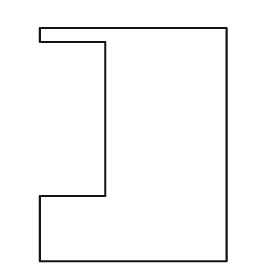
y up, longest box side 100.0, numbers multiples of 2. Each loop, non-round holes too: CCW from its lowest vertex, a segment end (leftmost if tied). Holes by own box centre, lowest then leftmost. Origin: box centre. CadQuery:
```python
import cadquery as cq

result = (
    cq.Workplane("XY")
    .moveTo(-40.0, -50.0)
    .lineTo(40.0, -50.0)
    .lineTo(40.0, 50.0)
    .lineTo(-40.0, 50.0)
    .lineTo(-40.0, 44.0)
    .lineTo(-12.0, 44.0)
    .lineTo(-12.0, -22.0)
    .lineTo(-40.0, -22.0)
    .close()
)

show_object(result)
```